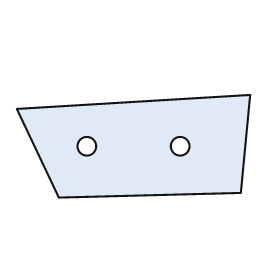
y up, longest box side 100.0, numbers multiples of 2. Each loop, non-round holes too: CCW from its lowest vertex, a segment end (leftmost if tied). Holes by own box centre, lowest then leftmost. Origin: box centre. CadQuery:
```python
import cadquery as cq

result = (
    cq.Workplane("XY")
    .moveTo(-32.0, -22.0)
    .lineTo(46.0, -20.0)
    .lineTo(50.0, 22.0)
    .lineTo(-50.0, 16.0)
    .close()
    .moveTo(-20.0, 0.0)
    .circle(4.0)
    .moveTo(20.0, 0.0)
    .circle(4.0)
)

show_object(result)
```